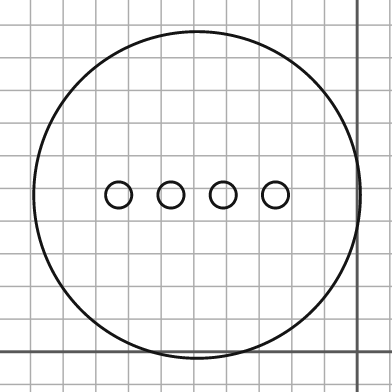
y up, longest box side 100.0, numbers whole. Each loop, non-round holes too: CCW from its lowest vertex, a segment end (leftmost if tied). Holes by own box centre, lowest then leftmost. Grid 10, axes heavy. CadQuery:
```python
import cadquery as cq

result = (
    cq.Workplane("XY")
    .moveTo(-49.0, 48.0)
    .circle(50.0)
    .moveTo(-73.0, 48.0)
    .circle(4.0)
    .moveTo(-57.0, 48.0)
    .circle(4.0)
    .moveTo(-41.0, 48.0)
    .circle(4.0)
    .moveTo(-25.0, 48.0)
    .circle(4.0)
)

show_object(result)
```